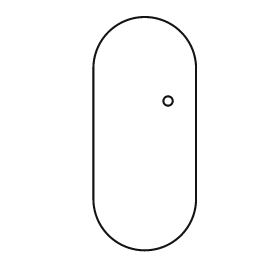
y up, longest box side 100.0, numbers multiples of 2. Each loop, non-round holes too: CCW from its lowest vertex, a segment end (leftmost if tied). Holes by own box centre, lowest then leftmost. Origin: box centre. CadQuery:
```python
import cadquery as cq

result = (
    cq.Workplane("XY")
    .moveTo(-22.0, -28.0)
    .threePointArc((0.0, -50.0), (22.0, -28.0))
    .lineTo(22.0, 28.0)
    .threePointArc((0.0, 50.0), (-22.0, 28.0))
    .close()
    .moveTo(10.0, 14.0)
    .circle(2.0)
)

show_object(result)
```